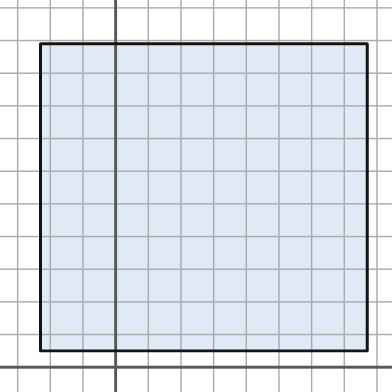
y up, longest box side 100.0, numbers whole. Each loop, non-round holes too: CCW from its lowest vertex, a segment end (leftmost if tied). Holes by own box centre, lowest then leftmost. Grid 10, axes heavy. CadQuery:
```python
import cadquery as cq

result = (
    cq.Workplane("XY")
    .moveTo(-23.0, 5.0)
    .lineTo(77.0, 5.0)
    .lineTo(77.0, 99.0)
    .lineTo(-23.0, 99.0)
    .close()
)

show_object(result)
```